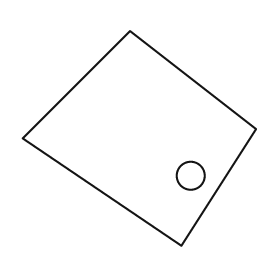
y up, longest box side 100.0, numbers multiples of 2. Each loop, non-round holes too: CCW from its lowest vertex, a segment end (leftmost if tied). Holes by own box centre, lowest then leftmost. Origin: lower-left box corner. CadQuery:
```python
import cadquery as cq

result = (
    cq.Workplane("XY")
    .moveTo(68.0, 0.0)
    .lineTo(100.0, 50.0)
    .lineTo(46.0, 92.0)
    .lineTo(0.0, 46.0)
    .close()
    .moveTo(72.0, 30.0)
    .circle(6.0)
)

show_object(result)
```